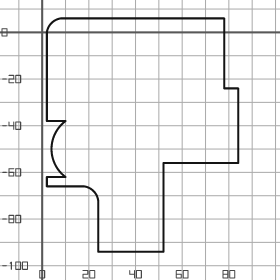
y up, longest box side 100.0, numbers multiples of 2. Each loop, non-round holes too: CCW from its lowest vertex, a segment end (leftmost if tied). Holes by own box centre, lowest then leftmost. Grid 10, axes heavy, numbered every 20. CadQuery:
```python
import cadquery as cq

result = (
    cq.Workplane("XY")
    .moveTo(24.0, -94.0)
    .lineTo(52.0, -94.0)
    .lineTo(52.0, -56.0)
    .lineTo(84.0, -56.0)
    .lineTo(84.0, -24.0)
    .lineTo(78.0, -24.0)
    .lineTo(78.0, 6.0)
    .lineTo(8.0, 6.0)
    .threePointArc((4.0, 4.0), (2.0, 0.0))
    .lineTo(2.0, -38.0)
    .lineTo(10.0, -38.0)
    .threePointArc((4.0, -50.0), (10.0, -62.0))
    .lineTo(2.0, -62.0)
    .lineTo(2.0, -66.0)
    .lineTo(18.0, -66.0)
    .threePointArc((22.0, -68.0), (24.0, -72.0))
    .close()
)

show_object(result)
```